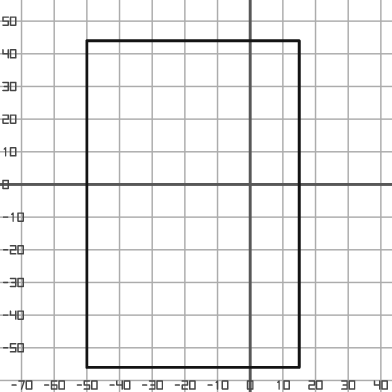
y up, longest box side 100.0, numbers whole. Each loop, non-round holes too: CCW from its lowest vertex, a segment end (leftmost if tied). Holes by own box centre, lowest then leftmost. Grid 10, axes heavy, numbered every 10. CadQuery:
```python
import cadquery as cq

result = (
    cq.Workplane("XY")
    .moveTo(-50.0, -56.0)
    .lineTo(15.0, -56.0)
    .lineTo(15.0, 44.0)
    .lineTo(-50.0, 44.0)
    .close()
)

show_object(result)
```